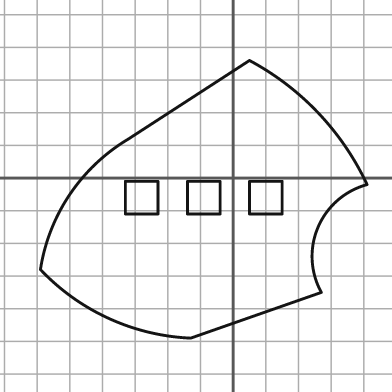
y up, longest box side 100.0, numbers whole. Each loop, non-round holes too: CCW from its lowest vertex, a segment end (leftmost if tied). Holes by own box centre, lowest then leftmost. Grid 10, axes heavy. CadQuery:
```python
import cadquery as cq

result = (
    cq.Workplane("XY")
    .moveTo(-13.0, -49.0)
    .lineTo(27.0, -35.0)
    .threePointArc((26.0, -15.0), (41.0, -2.0))
    .threePointArc((26.0, 20.0), (5.0, 36.0))
    .lineTo(-32.0, 12.0)
    .threePointArc((-50.0, -5.0), (-59.0, -28.0))
    .threePointArc((-38.0, -43.0), (-13.0, -49.0))
    .close()
    .moveTo(-33.0, -11.0)
    .lineTo(-23.0, -11.0)
    .lineTo(-23.0, -1.0)
    .lineTo(-33.0, -1.0)
    .close()
    .moveTo(-14.0, -11.0)
    .lineTo(-4.0, -11.0)
    .lineTo(-4.0, -1.0)
    .lineTo(-14.0, -1.0)
    .close()
    .moveTo(5.0, -11.0)
    .lineTo(15.0, -11.0)
    .lineTo(15.0, -1.0)
    .lineTo(5.0, -1.0)
    .close()
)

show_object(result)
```